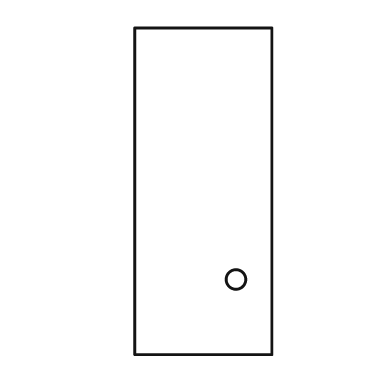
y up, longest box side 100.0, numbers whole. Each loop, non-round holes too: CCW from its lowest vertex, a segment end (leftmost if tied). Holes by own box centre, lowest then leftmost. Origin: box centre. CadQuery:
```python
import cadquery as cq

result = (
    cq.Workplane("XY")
    .moveTo(-21.0, -50.0)
    .lineTo(21.0, -50.0)
    .lineTo(21.0, 50.0)
    .lineTo(-21.0, 50.0)
    .close()
    .moveTo(10.0, -27.0)
    .circle(3.0)
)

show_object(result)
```